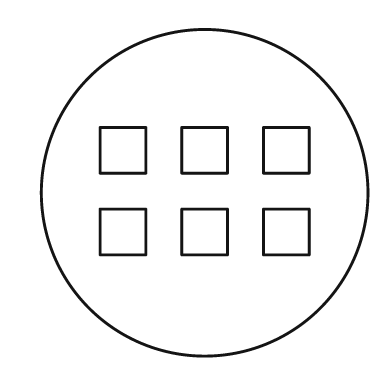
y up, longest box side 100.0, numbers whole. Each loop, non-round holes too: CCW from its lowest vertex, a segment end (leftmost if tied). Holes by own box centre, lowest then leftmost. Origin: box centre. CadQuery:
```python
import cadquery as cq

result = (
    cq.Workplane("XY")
    .moveTo(0.0, 0.0)
    .circle(50.0)
    .moveTo(-32.0, -19.0)
    .lineTo(-18.0, -19.0)
    .lineTo(-18.0, -5.0)
    .lineTo(-32.0, -5.0)
    .close()
    .moveTo(-7.0, -19.0)
    .lineTo(7.0, -19.0)
    .lineTo(7.0, -5.0)
    .lineTo(-7.0, -5.0)
    .close()
    .moveTo(18.0, -19.0)
    .lineTo(32.0, -19.0)
    .lineTo(32.0, -5.0)
    .lineTo(18.0, -5.0)
    .close()
    .moveTo(-32.0, 6.0)
    .lineTo(-18.0, 6.0)
    .lineTo(-18.0, 20.0)
    .lineTo(-32.0, 20.0)
    .close()
    .moveTo(-7.0, 6.0)
    .lineTo(7.0, 6.0)
    .lineTo(7.0, 20.0)
    .lineTo(-7.0, 20.0)
    .close()
    .moveTo(18.0, 6.0)
    .lineTo(32.0, 6.0)
    .lineTo(32.0, 20.0)
    .lineTo(18.0, 20.0)
    .close()
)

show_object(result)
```